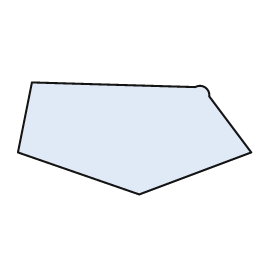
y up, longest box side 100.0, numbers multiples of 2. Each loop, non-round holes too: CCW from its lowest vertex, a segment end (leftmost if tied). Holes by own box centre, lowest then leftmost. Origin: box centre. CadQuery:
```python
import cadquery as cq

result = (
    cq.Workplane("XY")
    .moveTo(2.0, -24.0)
    .lineTo(50.0, -6.0)
    .lineTo(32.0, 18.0)
    .threePointArc((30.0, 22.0), (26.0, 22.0))
    .lineTo(-44.0, 24.0)
    .lineTo(-50.0, -6.0)
    .close()
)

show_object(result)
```